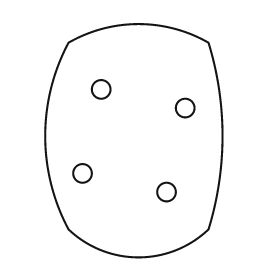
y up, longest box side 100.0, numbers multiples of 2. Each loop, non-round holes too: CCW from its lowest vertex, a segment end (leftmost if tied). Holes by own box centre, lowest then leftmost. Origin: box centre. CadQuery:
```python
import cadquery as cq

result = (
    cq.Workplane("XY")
    .moveTo(-28.0, -38.0)
    .threePointArc((2.0, -50.0), (32.0, -38.0))
    .threePointArc((38.0, 2.0), (32.0, 42.0))
    .threePointArc((2.0, 50.0), (-28.0, 42.0))
    .threePointArc((-38.0, 2.0), (-28.0, -38.0))
    .close()
    .moveTo(14.0, -22.0)
    .circle(4.0)
    .moveTo(-22.0, -14.0)
    .circle(4.0)
    .moveTo(22.0, 14.0)
    .circle(4.0)
    .moveTo(-14.0, 22.0)
    .circle(4.0)
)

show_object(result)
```